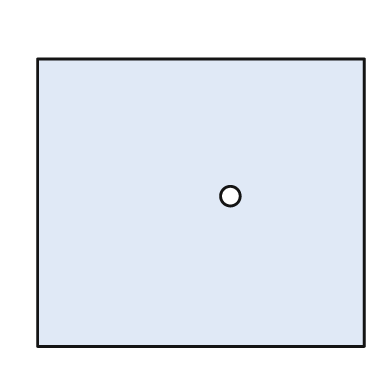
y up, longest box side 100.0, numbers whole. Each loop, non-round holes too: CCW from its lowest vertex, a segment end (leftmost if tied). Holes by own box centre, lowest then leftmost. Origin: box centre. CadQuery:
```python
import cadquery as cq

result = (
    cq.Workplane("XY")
    .moveTo(-50.0, -44.0)
    .lineTo(50.0, -44.0)
    .lineTo(50.0, 44.0)
    .lineTo(-50.0, 44.0)
    .close()
    .moveTo(9.0, 2.0)
    .circle(3.0)
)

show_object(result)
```